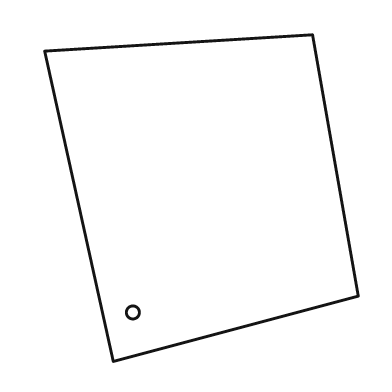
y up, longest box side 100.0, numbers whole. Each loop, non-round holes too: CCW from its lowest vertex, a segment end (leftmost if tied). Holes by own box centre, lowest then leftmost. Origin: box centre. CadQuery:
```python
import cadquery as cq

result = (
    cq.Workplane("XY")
    .moveTo(-27.0, -50.0)
    .lineTo(48.0, -30.0)
    .lineTo(34.0, 50.0)
    .lineTo(-48.0, 45.0)
    .close()
    .moveTo(-21.0, -35.0)
    .circle(2.0)
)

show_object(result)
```